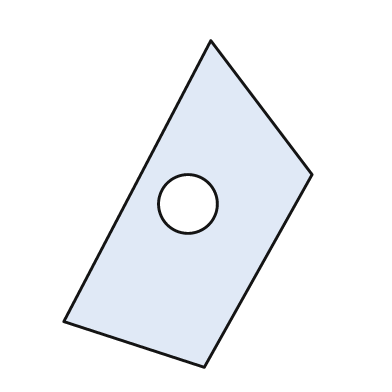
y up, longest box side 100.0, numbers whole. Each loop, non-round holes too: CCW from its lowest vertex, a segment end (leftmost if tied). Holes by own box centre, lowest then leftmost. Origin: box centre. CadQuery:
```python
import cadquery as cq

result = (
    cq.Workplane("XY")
    .moveTo(5.0, -50.0)
    .lineTo(38.0, 9.0)
    .lineTo(7.0, 50.0)
    .lineTo(-38.0, -36.0)
    .close()
    .moveTo(0.0, 0.0)
    .circle(9.0)
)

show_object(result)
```